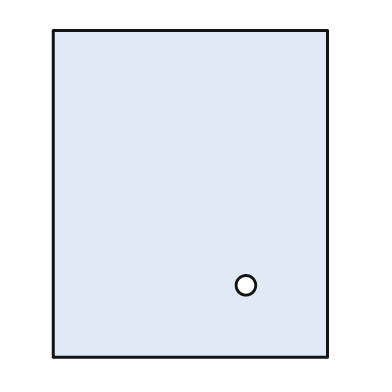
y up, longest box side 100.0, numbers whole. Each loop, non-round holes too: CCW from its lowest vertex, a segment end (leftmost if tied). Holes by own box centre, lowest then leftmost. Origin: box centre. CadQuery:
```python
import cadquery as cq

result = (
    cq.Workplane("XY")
    .moveTo(-42.0, -50.0)
    .lineTo(42.0, -50.0)
    .lineTo(42.0, 50.0)
    .lineTo(-42.0, 50.0)
    .close()
    .moveTo(17.0, -28.0)
    .circle(3.0)
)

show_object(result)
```